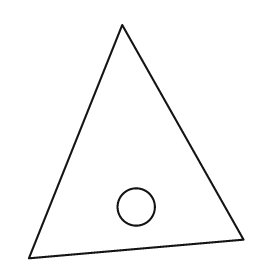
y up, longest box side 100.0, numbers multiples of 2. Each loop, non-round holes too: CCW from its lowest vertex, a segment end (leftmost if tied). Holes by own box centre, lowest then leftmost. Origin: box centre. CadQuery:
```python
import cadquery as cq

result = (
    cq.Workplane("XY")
    .moveTo(-46.0, -50.0)
    .lineTo(46.0, -42.0)
    .lineTo(-6.0, 50.0)
    .close()
    .moveTo(0.0, -28.0)
    .circle(8.0)
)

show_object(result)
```